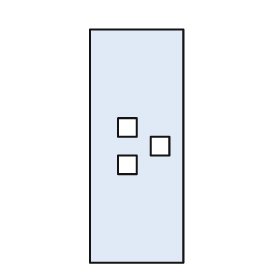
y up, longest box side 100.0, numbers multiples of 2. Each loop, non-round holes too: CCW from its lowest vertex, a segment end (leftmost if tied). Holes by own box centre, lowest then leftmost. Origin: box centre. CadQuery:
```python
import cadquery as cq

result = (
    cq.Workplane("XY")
    .moveTo(-20.0, -50.0)
    .lineTo(20.0, -50.0)
    .lineTo(20.0, 50.0)
    .lineTo(-20.0, 50.0)
    .close()
    .moveTo(-8.0, -12.0)
    .lineTo(0.0, -12.0)
    .lineTo(0.0, -4.0)
    .lineTo(-8.0, -4.0)
    .close()
    .moveTo(6.0, -4.0)
    .lineTo(14.0, -4.0)
    .lineTo(14.0, 4.0)
    .lineTo(6.0, 4.0)
    .close()
    .moveTo(-8.0, 4.0)
    .lineTo(0.0, 4.0)
    .lineTo(0.0, 12.0)
    .lineTo(-8.0, 12.0)
    .close()
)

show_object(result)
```